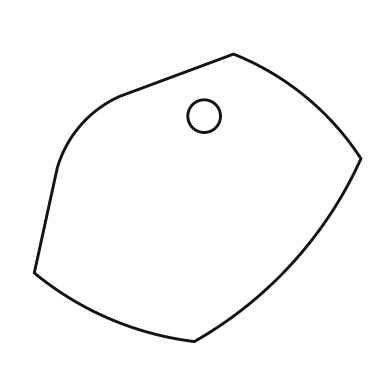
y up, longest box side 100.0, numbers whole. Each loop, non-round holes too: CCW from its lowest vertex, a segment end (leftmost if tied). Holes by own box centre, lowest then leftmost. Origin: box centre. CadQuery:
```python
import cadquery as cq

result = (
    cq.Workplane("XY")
    .moveTo(-1.0, -44.0)
    .threePointArc((29.0, -20.0), (50.0, 12.0))
    .threePointArc((33.0, 31.0), (11.0, 44.0))
    .lineTo(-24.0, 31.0)
    .threePointArc((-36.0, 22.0), (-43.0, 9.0))
    .lineTo(-50.0, -23.0)
    .threePointArc((-27.0, -37.0), (-1.0, -44.0))
    .close()
    .moveTo(2.0, 25.0)
    .circle(5.0)
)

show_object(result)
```